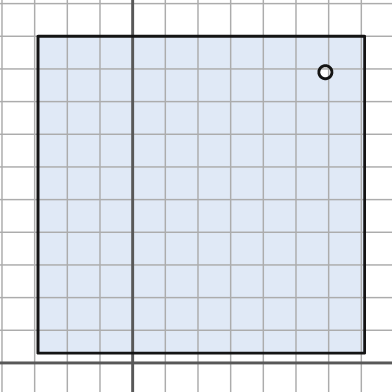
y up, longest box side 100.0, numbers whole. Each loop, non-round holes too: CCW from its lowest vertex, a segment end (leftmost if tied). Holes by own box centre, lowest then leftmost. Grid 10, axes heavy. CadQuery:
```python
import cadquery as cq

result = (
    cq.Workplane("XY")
    .moveTo(-29.0, 3.0)
    .lineTo(71.0, 3.0)
    .lineTo(71.0, 100.0)
    .lineTo(-29.0, 100.0)
    .close()
    .moveTo(59.0, 89.0)
    .circle(2.0)
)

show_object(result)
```